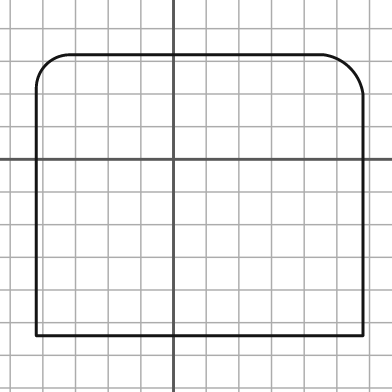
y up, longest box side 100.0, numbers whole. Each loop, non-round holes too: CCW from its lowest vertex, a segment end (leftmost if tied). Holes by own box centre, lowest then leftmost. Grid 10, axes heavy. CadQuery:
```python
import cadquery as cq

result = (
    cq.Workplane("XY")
    .moveTo(-42.0, -54.0)
    .lineTo(58.0, -54.0)
    .lineTo(58.0, 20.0)
    .threePointArc((54.0, 28.0), (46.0, 32.0))
    .lineTo(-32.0, 32.0)
    .threePointArc((-39.0, 29.0), (-42.0, 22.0))
    .close()
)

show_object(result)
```